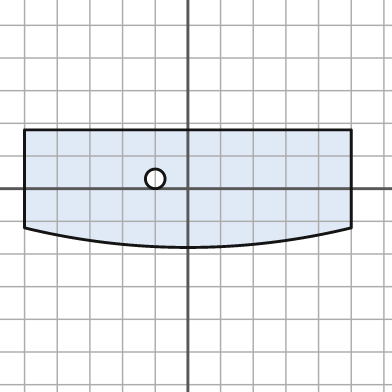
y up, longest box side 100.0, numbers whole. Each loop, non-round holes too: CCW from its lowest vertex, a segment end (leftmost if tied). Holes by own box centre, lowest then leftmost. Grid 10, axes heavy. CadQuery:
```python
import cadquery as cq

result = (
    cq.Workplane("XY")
    .moveTo(-50.0, -12.0)
    .threePointArc((0.0, -18.0), (50.0, -12.0))
    .lineTo(50.0, 18.0)
    .lineTo(-50.0, 18.0)
    .close()
    .moveTo(-10.0, 3.0)
    .circle(3.0)
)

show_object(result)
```